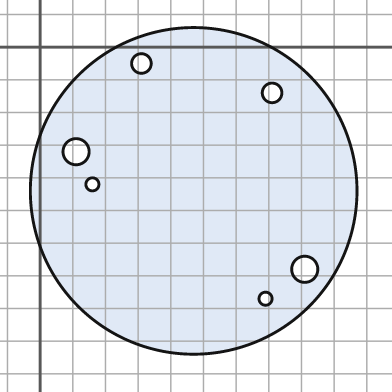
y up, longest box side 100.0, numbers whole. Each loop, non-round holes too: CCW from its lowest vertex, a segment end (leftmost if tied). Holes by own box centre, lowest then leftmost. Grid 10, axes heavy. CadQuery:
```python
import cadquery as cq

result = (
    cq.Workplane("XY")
    .moveTo(47.0, -44.0)
    .circle(50.0)
    .moveTo(69.0, -77.0)
    .circle(2.0)
    .moveTo(81.0, -68.0)
    .circle(4.0)
    .moveTo(16.0, -42.0)
    .circle(2.0)
    .moveTo(11.0, -32.0)
    .circle(4.0)
    .moveTo(71.0, -14.0)
    .circle(3.0)
    .moveTo(31.0, -5.0)
    .circle(3.0)
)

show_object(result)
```